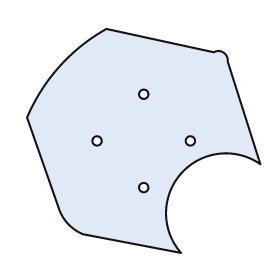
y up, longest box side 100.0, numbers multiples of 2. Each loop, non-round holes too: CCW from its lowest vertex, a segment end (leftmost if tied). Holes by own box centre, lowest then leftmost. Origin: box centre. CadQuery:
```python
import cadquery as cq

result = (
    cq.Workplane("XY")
    .moveTo(16.0, -48.0)
    .threePointArc((16.0, -14.0), (50.0, -10.0))
    .lineTo(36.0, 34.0)
    .threePointArc((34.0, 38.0), (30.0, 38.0))
    .lineTo(-16.0, 48.0)
    .threePointArc((-36.0, 32.0), (-50.0, 10.0))
    .lineTo(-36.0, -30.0)
    .threePointArc((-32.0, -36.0), (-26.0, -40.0))
    .close()
    .moveTo(0.0, -20.0)
    .circle(2.0)
    .moveTo(-20.0, 0.0)
    .circle(2.0)
    .moveTo(20.0, 0.0)
    .circle(2.0)
    .moveTo(0.0, 20.0)
    .circle(2.0)
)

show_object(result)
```